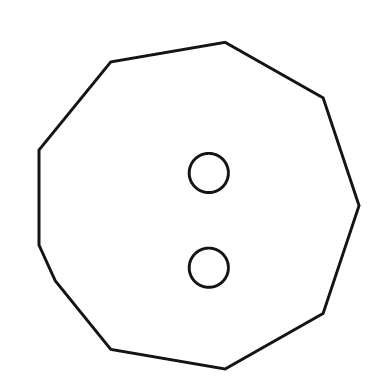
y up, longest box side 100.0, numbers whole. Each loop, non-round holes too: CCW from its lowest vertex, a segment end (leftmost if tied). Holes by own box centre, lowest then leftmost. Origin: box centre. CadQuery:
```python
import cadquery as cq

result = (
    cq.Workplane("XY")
    .moveTo(8.0, -50.0)
    .lineTo(38.0, -33.0)
    .lineTo(49.0, 0.0)
    .lineTo(38.0, 33.0)
    .lineTo(8.0, 50.0)
    .lineTo(-27.0, 44.0)
    .lineTo(-49.0, 17.0)
    .lineTo(-49.0, -12.0)
    .lineTo(-44.0, -23.0)
    .lineTo(-27.0, -44.0)
    .close()
    .moveTo(3.0, -19.0)
    .circle(6.0)
    .moveTo(3.0, 10.0)
    .circle(6.0)
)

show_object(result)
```